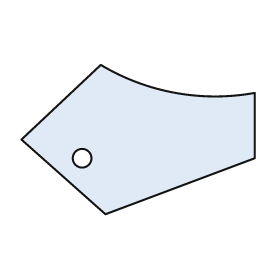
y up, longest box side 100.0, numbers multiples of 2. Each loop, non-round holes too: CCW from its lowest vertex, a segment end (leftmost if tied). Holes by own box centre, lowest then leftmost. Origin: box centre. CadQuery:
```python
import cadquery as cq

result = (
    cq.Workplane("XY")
    .moveTo(-14.0, -32.0)
    .lineTo(50.0, -8.0)
    .lineTo(50.0, 20.0)
    .threePointArc((16.0, 20.0), (-16.0, 32.0))
    .lineTo(-50.0, 0.0)
    .close()
    .moveTo(-24.0, -8.0)
    .circle(4.0)
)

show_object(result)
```